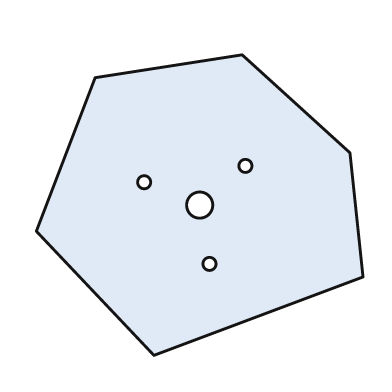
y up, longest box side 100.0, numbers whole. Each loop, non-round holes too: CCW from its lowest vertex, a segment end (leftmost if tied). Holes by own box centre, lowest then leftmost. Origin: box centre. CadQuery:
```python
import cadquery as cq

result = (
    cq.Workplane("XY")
    .moveTo(-14.0, -46.0)
    .lineTo(50.0, -22.0)
    .lineTo(46.0, 16.0)
    .lineTo(13.0, 46.0)
    .lineTo(-32.0, 39.0)
    .lineTo(-50.0, -8.0)
    .close()
    .moveTo(3.0, -18.0)
    .circle(2.0)
    .moveTo(0.0, 0.0)
    .circle(4.0)
    .moveTo(-17.0, 7.0)
    .circle(2.0)
    .moveTo(14.0, 12.0)
    .circle(2.0)
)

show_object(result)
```